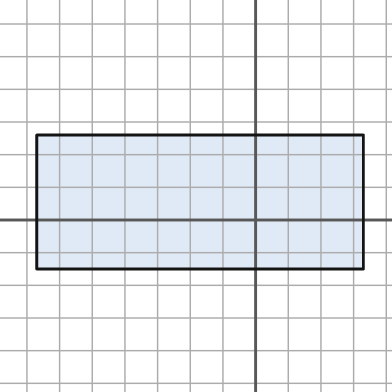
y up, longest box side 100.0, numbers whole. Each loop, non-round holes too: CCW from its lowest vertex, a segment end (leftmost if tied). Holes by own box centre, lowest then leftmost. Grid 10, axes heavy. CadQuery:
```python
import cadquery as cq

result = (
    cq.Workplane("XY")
    .moveTo(-67.0, -15.0)
    .lineTo(33.0, -15.0)
    .lineTo(33.0, 26.0)
    .lineTo(-67.0, 26.0)
    .close()
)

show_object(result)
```